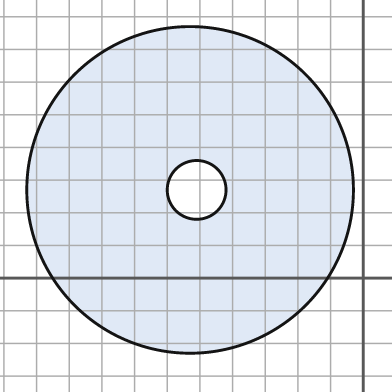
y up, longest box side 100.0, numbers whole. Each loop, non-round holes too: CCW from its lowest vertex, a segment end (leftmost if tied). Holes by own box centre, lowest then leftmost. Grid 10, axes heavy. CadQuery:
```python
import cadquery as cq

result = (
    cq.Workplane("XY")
    .moveTo(-53.0, 27.0)
    .circle(50.0)
    .moveTo(-51.0, 27.0)
    .circle(9.0)
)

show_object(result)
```